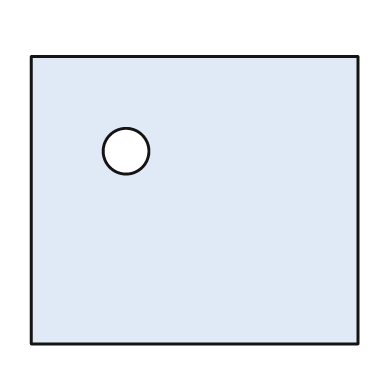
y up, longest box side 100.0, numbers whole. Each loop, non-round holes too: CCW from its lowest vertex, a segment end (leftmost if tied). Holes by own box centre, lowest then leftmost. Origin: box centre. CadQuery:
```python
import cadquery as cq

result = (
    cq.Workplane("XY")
    .moveTo(-50.0, -44.0)
    .lineTo(50.0, -44.0)
    .lineTo(50.0, 44.0)
    .lineTo(-50.0, 44.0)
    .close()
    .moveTo(-21.0, 15.0)
    .circle(7.0)
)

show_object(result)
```